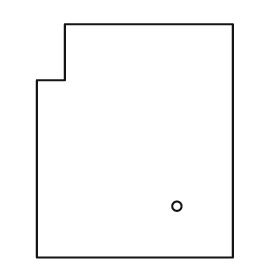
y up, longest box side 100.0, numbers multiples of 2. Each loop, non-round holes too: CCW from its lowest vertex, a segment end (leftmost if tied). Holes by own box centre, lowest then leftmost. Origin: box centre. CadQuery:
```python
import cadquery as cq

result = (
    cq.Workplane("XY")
    .moveTo(-42.0, -50.0)
    .lineTo(42.0, -50.0)
    .lineTo(42.0, 50.0)
    .lineTo(-30.0, 50.0)
    .lineTo(-30.0, 26.0)
    .lineTo(-42.0, 26.0)
    .close()
    .moveTo(18.0, -28.0)
    .circle(2.0)
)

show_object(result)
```